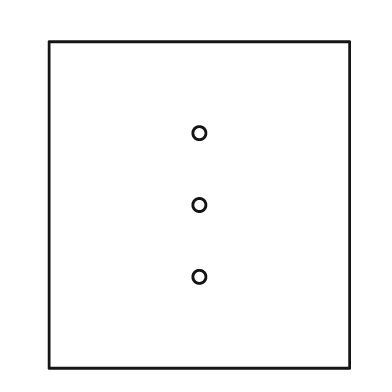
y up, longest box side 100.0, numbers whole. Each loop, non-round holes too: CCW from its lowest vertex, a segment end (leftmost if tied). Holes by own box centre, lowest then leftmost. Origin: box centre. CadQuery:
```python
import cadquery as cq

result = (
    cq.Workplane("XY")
    .moveTo(-46.0, -50.0)
    .lineTo(46.0, -50.0)
    .lineTo(46.0, 50.0)
    .lineTo(-46.0, 50.0)
    .close()
    .moveTo(0.0, -22.0)
    .circle(2.0)
    .moveTo(0.0, 0.0)
    .circle(2.0)
    .moveTo(0.0, 22.0)
    .circle(2.0)
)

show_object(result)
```